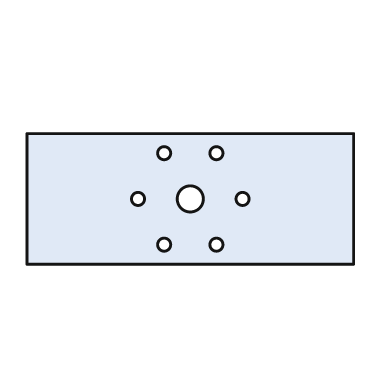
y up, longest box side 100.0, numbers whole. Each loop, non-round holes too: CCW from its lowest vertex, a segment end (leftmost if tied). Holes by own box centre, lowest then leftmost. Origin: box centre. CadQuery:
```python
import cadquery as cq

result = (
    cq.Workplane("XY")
    .moveTo(-50.0, -20.0)
    .lineTo(50.0, -20.0)
    .lineTo(50.0, 20.0)
    .lineTo(-50.0, 20.0)
    .close()
    .moveTo(-8.0, -14.0)
    .circle(2.0)
    .moveTo(8.0, -14.0)
    .circle(2.0)
    .moveTo(-16.0, 0.0)
    .circle(2.0)
    .moveTo(0.0, 0.0)
    .circle(4.0)
    .moveTo(16.0, 0.0)
    .circle(2.0)
    .moveTo(-8.0, 14.0)
    .circle(2.0)
    .moveTo(8.0, 14.0)
    .circle(2.0)
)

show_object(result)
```